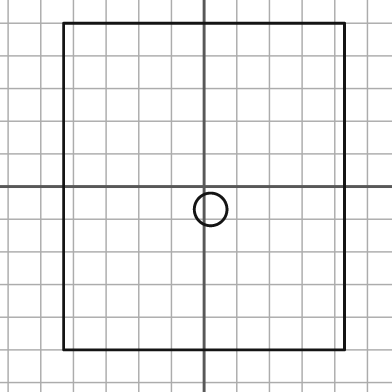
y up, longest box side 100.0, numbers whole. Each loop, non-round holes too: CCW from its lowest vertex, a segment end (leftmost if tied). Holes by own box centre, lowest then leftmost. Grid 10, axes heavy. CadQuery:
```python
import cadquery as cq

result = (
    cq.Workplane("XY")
    .moveTo(-43.0, -50.0)
    .lineTo(43.0, -50.0)
    .lineTo(43.0, 50.0)
    .lineTo(-43.0, 50.0)
    .close()
    .moveTo(2.0, -7.0)
    .circle(5.0)
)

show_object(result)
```